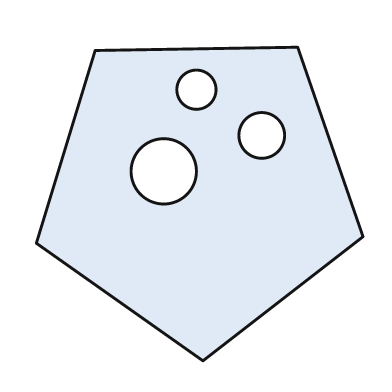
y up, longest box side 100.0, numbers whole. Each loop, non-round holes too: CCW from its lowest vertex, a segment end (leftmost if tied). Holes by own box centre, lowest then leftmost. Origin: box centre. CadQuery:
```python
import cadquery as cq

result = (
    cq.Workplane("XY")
    .moveTo(1.0, -48.0)
    .lineTo(50.0, -10.0)
    .lineTo(30.0, 48.0)
    .lineTo(-32.0, 47.0)
    .lineTo(-50.0, -12.0)
    .close()
    .moveTo(-11.0, 10.0)
    .circle(10.0)
    .moveTo(19.0, 21.0)
    .circle(7.0)
    .moveTo(-1.0, 35.0)
    .circle(6.0)
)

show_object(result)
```